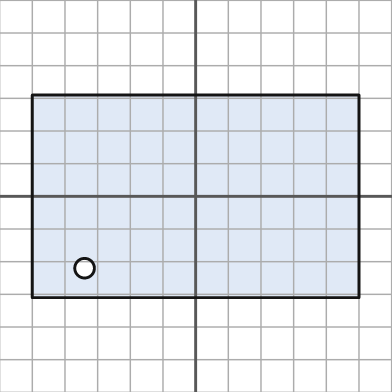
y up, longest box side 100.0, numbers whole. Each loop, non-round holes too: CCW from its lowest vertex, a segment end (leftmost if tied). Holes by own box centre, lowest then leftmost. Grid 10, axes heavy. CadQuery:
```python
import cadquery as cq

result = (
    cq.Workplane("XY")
    .moveTo(-50.0, -31.0)
    .lineTo(50.0, -31.0)
    .lineTo(50.0, 31.0)
    .lineTo(-50.0, 31.0)
    .close()
    .moveTo(-34.0, -22.0)
    .circle(3.0)
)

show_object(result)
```